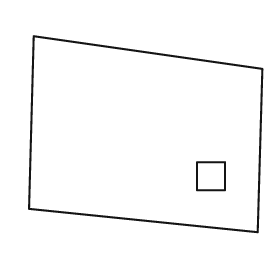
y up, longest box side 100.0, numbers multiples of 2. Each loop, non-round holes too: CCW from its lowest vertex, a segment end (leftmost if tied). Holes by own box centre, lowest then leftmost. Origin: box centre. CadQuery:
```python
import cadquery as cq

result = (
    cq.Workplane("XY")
    .moveTo(48.0, -42.0)
    .lineTo(50.0, 28.0)
    .lineTo(-48.0, 42.0)
    .lineTo(-50.0, -32.0)
    .close()
    .moveTo(22.0, -24.0)
    .lineTo(34.0, -24.0)
    .lineTo(34.0, -12.0)
    .lineTo(22.0, -12.0)
    .close()
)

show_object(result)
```